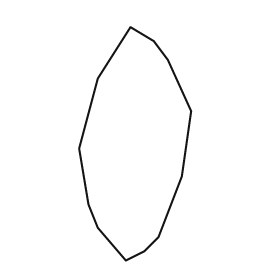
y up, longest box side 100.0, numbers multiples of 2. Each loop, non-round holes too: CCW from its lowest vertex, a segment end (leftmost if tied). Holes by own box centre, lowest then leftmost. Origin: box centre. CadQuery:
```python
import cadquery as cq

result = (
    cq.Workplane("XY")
    .moveTo(-4.0, -50.0)
    .lineTo(4.0, -46.0)
    .lineTo(10.0, -40.0)
    .lineTo(20.0, -14.0)
    .lineTo(24.0, 14.0)
    .lineTo(14.0, 36.0)
    .lineTo(8.0, 44.0)
    .lineTo(-2.0, 50.0)
    .lineTo(-16.0, 28.0)
    .lineTo(-24.0, -2.0)
    .lineTo(-20.0, -26.0)
    .lineTo(-16.0, -36.0)
    .close()
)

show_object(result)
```